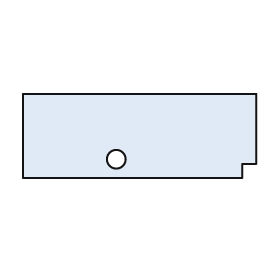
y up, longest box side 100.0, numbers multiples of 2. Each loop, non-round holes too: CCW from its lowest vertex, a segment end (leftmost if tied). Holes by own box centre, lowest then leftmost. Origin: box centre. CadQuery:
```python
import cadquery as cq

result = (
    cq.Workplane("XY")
    .moveTo(-50.0, -18.0)
    .lineTo(44.0, -18.0)
    .lineTo(44.0, -12.0)
    .lineTo(50.0, -12.0)
    .lineTo(50.0, 18.0)
    .lineTo(-50.0, 18.0)
    .close()
    .moveTo(-10.0, -10.0)
    .circle(4.0)
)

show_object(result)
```